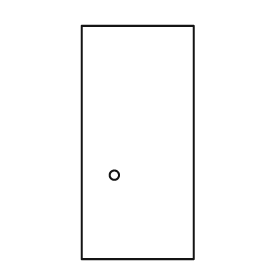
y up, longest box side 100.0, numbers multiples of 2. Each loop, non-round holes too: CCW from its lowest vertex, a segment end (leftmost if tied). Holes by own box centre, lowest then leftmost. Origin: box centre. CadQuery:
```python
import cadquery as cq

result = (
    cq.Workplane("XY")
    .moveTo(-24.0, -50.0)
    .lineTo(24.0, -50.0)
    .lineTo(24.0, 50.0)
    .lineTo(-24.0, 50.0)
    .close()
    .moveTo(-10.0, -14.0)
    .circle(2.0)
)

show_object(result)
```